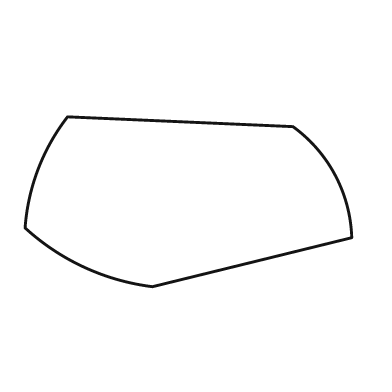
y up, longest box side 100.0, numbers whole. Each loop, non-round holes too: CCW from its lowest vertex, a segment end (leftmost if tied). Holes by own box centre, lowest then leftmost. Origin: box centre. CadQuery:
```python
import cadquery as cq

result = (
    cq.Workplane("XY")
    .moveTo(-11.0, -26.0)
    .lineTo(50.0, -11.0)
    .threePointArc((45.0, 8.0), (32.0, 23.0))
    .lineTo(-37.0, 26.0)
    .threePointArc((-46.0, 10.0), (-50.0, -8.0))
    .threePointArc((-32.0, -20.0), (-11.0, -26.0))
    .close()
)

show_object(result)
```